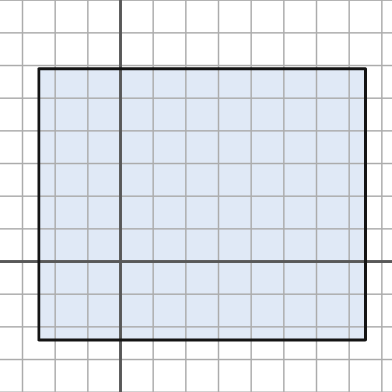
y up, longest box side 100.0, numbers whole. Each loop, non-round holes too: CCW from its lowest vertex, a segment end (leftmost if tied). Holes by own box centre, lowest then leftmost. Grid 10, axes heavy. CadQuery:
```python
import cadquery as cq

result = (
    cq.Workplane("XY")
    .moveTo(-25.0, -24.0)
    .lineTo(75.0, -24.0)
    .lineTo(75.0, 59.0)
    .lineTo(-25.0, 59.0)
    .close()
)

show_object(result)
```